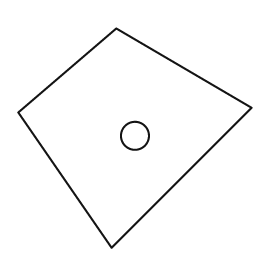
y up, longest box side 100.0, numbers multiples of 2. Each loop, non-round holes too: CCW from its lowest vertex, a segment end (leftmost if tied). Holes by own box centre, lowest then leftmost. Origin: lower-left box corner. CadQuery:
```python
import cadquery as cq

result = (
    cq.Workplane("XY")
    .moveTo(40.0, 0.0)
    .lineTo(100.0, 60.0)
    .lineTo(42.0, 94.0)
    .lineTo(0.0, 58.0)
    .close()
    .moveTo(50.0, 48.0)
    .circle(6.0)
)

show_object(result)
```